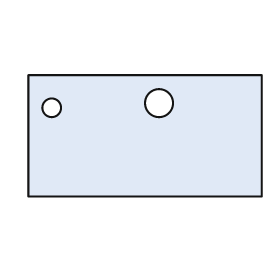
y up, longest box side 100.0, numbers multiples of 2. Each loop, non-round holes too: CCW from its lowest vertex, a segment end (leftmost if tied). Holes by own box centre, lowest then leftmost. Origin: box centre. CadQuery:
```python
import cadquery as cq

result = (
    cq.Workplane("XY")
    .moveTo(-50.0, -26.0)
    .lineTo(50.0, -26.0)
    .lineTo(50.0, 26.0)
    .lineTo(-50.0, 26.0)
    .close()
    .moveTo(-40.0, 12.0)
    .circle(4.0)
    .moveTo(6.0, 14.0)
    .circle(6.0)
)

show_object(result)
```